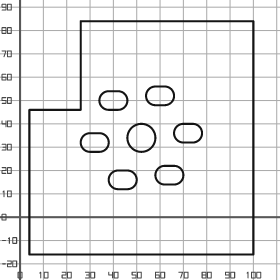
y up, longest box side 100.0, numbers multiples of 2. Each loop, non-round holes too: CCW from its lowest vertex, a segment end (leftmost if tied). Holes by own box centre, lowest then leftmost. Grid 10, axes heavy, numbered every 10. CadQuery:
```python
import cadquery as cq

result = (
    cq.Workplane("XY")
    .moveTo(4.0, -16.0)
    .lineTo(100.0, -16.0)
    .lineTo(100.0, 84.0)
    .lineTo(26.0, 84.0)
    .lineTo(26.0, 46.0)
    .lineTo(4.0, 46.0)
    .close()
    .moveTo(42.0, 12.0)
    .lineTo(46.0, 12.0)
    .threePointArc((50.0, 16.0), (46.0, 20.0))
    .lineTo(42.0, 20.0)
    .threePointArc((38.0, 16.0), (42.0, 12.0))
    .close()
    .moveTo(62.0, 14.0)
    .lineTo(66.0, 14.0)
    .threePointArc((70.0, 18.0), (66.0, 22.0))
    .lineTo(62.0, 22.0)
    .threePointArc((58.0, 18.0), (62.0, 14.0))
    .close()
    .moveTo(30.0, 28.0)
    .lineTo(34.0, 28.0)
    .threePointArc((38.0, 32.0), (34.0, 36.0))
    .lineTo(30.0, 36.0)
    .threePointArc((26.0, 32.0), (30.0, 28.0))
    .close()
    .moveTo(52.0, 34.0)
    .circle(6.0)
    .moveTo(70.0, 32.0)
    .lineTo(74.0, 32.0)
    .threePointArc((78.0, 36.0), (74.0, 40.0))
    .lineTo(70.0, 40.0)
    .threePointArc((66.0, 36.0), (70.0, 32.0))
    .close()
    .moveTo(38.0, 46.0)
    .lineTo(42.0, 46.0)
    .threePointArc((46.0, 50.0), (42.0, 54.0))
    .lineTo(38.0, 54.0)
    .threePointArc((34.0, 50.0), (38.0, 46.0))
    .close()
    .moveTo(58.0, 48.0)
    .lineTo(62.0, 48.0)
    .threePointArc((66.0, 52.0), (62.0, 56.0))
    .lineTo(58.0, 56.0)
    .threePointArc((54.0, 52.0), (58.0, 48.0))
    .close()
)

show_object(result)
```